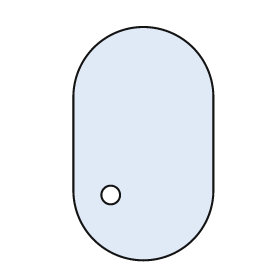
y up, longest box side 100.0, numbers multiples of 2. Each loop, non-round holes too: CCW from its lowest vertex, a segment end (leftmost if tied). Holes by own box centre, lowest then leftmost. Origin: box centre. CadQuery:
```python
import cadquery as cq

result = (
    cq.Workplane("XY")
    .moveTo(-30.0, -20.0)
    .threePointArc((0.0, -50.0), (30.0, -20.0))
    .lineTo(30.0, 20.0)
    .threePointArc((0.0, 50.0), (-30.0, 20.0))
    .close()
    .moveTo(-14.0, -22.0)
    .circle(4.0)
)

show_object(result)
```